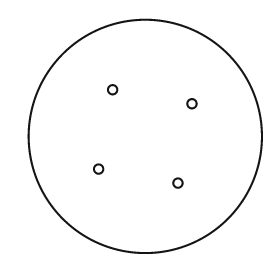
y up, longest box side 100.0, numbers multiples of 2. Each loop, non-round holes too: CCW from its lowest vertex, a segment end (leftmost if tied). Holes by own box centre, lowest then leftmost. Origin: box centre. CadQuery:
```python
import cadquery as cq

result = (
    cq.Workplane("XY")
    .moveTo(0.0, 0.0)
    .circle(50.0)
    .moveTo(14.0, -20.0)
    .circle(2.0)
    .moveTo(-20.0, -14.0)
    .circle(2.0)
    .moveTo(20.0, 14.0)
    .circle(2.0)
    .moveTo(-14.0, 20.0)
    .circle(2.0)
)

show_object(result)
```